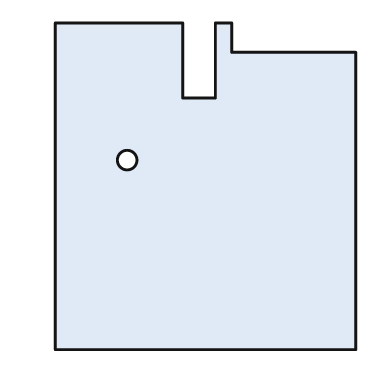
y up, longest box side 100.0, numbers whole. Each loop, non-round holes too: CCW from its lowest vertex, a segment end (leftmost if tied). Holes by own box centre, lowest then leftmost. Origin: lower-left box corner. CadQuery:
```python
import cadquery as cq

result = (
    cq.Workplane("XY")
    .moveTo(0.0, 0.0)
    .lineTo(92.0, 0.0)
    .lineTo(92.0, 91.0)
    .lineTo(54.0, 91.0)
    .lineTo(54.0, 100.0)
    .lineTo(49.0, 100.0)
    .lineTo(49.0, 77.0)
    .lineTo(39.0, 77.0)
    .lineTo(39.0, 100.0)
    .lineTo(0.0, 100.0)
    .close()
    .moveTo(22.0, 58.0)
    .circle(3.0)
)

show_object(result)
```